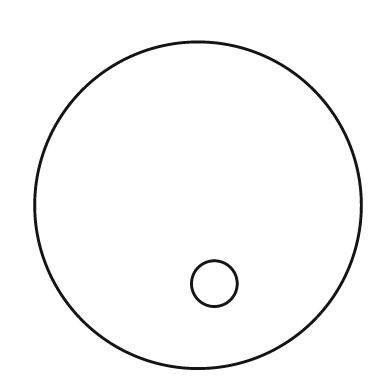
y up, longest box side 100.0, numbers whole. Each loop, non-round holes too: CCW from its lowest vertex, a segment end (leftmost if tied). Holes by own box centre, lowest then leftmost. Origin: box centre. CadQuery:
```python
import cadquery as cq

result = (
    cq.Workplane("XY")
    .moveTo(0.0, 0.0)
    .circle(50.0)
    .moveTo(5.0, -24.0)
    .circle(7.0)
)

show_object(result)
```